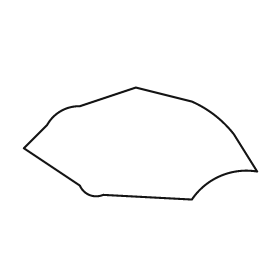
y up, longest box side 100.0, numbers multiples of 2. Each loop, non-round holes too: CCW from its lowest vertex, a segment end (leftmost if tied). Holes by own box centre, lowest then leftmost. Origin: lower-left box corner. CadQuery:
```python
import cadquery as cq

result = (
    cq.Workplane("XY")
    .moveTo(72.0, 0.0)
    .threePointArc((84.0, 10.0), (100.0, 12.0))
    .lineTo(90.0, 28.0)
    .threePointArc((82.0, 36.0), (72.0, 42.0))
    .lineTo(48.0, 48.0)
    .lineTo(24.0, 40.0)
    .threePointArc((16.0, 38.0), (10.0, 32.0))
    .lineTo(0.0, 22.0)
    .lineTo(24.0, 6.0)
    .threePointArc((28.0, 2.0), (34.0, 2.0))
    .close()
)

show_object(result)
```